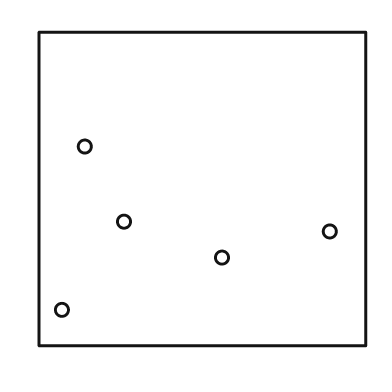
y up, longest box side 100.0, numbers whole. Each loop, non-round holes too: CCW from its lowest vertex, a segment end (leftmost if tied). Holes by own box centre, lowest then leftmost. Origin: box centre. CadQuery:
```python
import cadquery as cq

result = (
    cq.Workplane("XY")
    .moveTo(-50.0, -48.0)
    .lineTo(50.0, -48.0)
    .lineTo(50.0, 48.0)
    .lineTo(-50.0, 48.0)
    .close()
    .moveTo(-43.0, -37.0)
    .circle(2.0)
    .moveTo(6.0, -21.0)
    .circle(2.0)
    .moveTo(39.0, -13.0)
    .circle(2.0)
    .moveTo(-24.0, -10.0)
    .circle(2.0)
    .moveTo(-36.0, 13.0)
    .circle(2.0)
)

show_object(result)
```